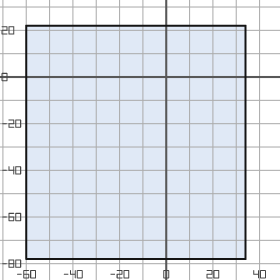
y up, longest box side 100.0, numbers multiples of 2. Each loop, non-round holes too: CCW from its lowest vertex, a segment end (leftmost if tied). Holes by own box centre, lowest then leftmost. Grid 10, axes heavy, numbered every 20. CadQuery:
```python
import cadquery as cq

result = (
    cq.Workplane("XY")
    .moveTo(-60.0, -78.0)
    .lineTo(34.0, -78.0)
    .lineTo(34.0, 22.0)
    .lineTo(-60.0, 22.0)
    .close()
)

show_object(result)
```